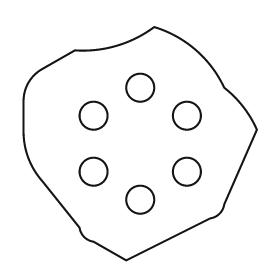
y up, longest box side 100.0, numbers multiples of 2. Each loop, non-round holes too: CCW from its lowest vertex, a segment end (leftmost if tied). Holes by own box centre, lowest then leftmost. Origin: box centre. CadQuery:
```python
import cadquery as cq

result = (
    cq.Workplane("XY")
    .moveTo(-6.0, -50.0)
    .lineTo(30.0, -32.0)
    .threePointArc((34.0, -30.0), (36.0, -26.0))
    .lineTo(50.0, 6.0)
    .threePointArc((44.0, 16.0), (36.0, 24.0))
    .threePointArc((24.0, 40.0), (6.0, 50.0))
    .threePointArc((-10.0, 42.0), (-28.0, 40.0))
    .lineTo(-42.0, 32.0)
    .threePointArc((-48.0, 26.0), (-50.0, 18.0))
    .lineTo(-50.0, 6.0)
    .threePointArc((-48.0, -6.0), (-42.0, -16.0))
    .lineTo(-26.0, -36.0)
    .threePointArc((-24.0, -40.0), (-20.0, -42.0))
    .close()
    .moveTo(0.0, -24.0)
    .circle(6.0)
    .moveTo(-20.0, -12.0)
    .circle(6.0)
    .moveTo(20.0, -12.0)
    .circle(6.0)
    .moveTo(-20.0, 12.0)
    .circle(6.0)
    .moveTo(20.0, 12.0)
    .circle(6.0)
    .moveTo(0.0, 24.0)
    .circle(6.0)
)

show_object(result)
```